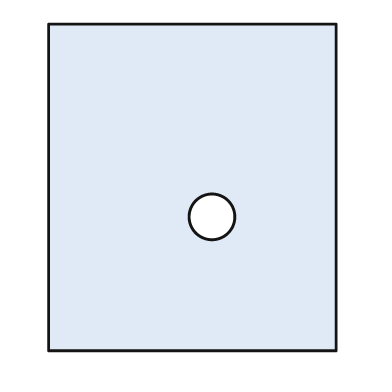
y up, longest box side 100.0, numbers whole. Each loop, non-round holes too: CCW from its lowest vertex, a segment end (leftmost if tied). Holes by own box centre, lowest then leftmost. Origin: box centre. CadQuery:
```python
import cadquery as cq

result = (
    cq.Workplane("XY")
    .moveTo(-44.0, -50.0)
    .lineTo(44.0, -50.0)
    .lineTo(44.0, 50.0)
    .lineTo(-44.0, 50.0)
    .close()
    .moveTo(6.0, -9.0)
    .circle(7.0)
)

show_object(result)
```